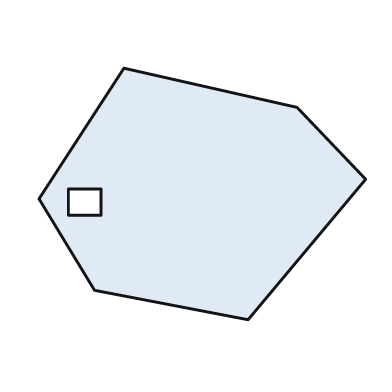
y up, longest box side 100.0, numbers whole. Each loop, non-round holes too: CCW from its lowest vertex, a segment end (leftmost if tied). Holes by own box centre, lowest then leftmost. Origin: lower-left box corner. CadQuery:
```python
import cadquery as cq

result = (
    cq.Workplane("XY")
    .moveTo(64.0, 0.0)
    .lineTo(100.0, 43.0)
    .lineTo(79.0, 65.0)
    .lineTo(26.0, 77.0)
    .lineTo(0.0, 37.0)
    .lineTo(17.0, 9.0)
    .close()
    .moveTo(9.0, 32.0)
    .lineTo(19.0, 32.0)
    .lineTo(19.0, 40.0)
    .lineTo(9.0, 40.0)
    .close()
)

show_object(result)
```